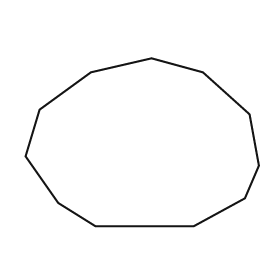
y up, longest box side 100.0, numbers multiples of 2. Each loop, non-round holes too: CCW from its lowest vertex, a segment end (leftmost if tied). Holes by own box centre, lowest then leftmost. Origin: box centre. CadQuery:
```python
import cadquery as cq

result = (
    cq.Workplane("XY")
    .moveTo(-20.0, -36.0)
    .lineTo(22.0, -36.0)
    .lineTo(44.0, -24.0)
    .lineTo(50.0, -10.0)
    .lineTo(46.0, 12.0)
    .lineTo(26.0, 30.0)
    .lineTo(4.0, 36.0)
    .lineTo(-22.0, 30.0)
    .lineTo(-44.0, 14.0)
    .lineTo(-50.0, -6.0)
    .lineTo(-36.0, -26.0)
    .close()
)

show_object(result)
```